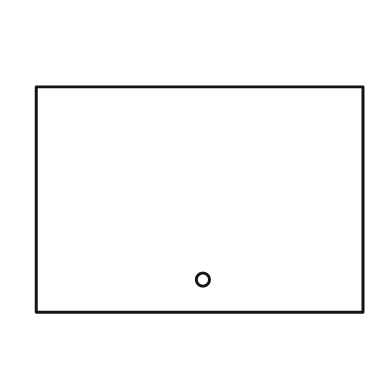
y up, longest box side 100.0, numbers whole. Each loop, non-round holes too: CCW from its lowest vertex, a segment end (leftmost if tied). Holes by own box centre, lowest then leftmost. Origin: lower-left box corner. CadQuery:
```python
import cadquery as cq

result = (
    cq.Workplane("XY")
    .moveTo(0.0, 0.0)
    .lineTo(100.0, 0.0)
    .lineTo(100.0, 69.0)
    .lineTo(0.0, 69.0)
    .close()
    .moveTo(51.0, 10.0)
    .circle(2.0)
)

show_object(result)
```